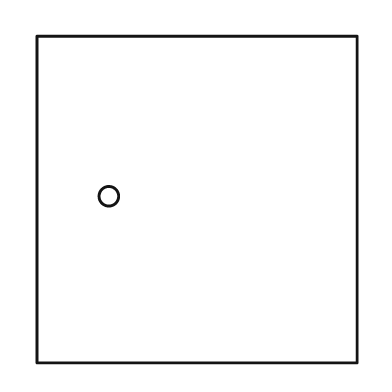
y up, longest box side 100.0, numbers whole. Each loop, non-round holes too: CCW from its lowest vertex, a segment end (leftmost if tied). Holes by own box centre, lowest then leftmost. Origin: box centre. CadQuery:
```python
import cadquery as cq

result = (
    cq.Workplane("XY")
    .moveTo(-49.0, -50.0)
    .lineTo(49.0, -50.0)
    .lineTo(49.0, 50.0)
    .lineTo(-49.0, 50.0)
    .close()
    .moveTo(-27.0, 1.0)
    .circle(3.0)
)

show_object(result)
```